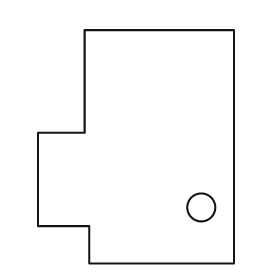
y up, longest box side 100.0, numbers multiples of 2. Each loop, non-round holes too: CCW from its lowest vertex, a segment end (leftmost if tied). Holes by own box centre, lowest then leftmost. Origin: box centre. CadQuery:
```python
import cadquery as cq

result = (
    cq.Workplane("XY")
    .moveTo(-20.0, -50.0)
    .lineTo(42.0, -50.0)
    .lineTo(42.0, 50.0)
    .lineTo(-22.0, 50.0)
    .lineTo(-22.0, 6.0)
    .lineTo(-42.0, 6.0)
    .lineTo(-42.0, -34.0)
    .lineTo(-20.0, -34.0)
    .close()
    .moveTo(28.0, -26.0)
    .circle(6.0)
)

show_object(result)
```